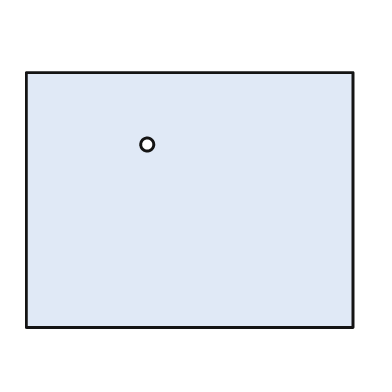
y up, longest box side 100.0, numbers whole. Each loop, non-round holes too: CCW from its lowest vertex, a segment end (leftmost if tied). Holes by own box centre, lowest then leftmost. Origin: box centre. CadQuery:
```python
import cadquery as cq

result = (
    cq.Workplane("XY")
    .moveTo(-50.0, -39.0)
    .lineTo(50.0, -39.0)
    .lineTo(50.0, 39.0)
    .lineTo(-50.0, 39.0)
    .close()
    .moveTo(-13.0, 17.0)
    .circle(2.0)
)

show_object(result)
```